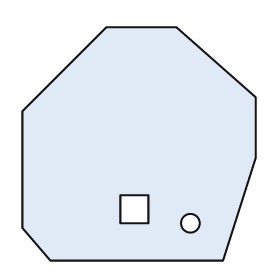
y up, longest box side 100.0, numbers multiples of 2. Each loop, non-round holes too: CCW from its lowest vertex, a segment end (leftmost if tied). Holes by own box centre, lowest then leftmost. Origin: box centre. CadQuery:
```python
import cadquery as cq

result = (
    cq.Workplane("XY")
    .moveTo(-38.0, -50.0)
    .lineTo(36.0, -50.0)
    .lineTo(50.0, -6.0)
    .lineTo(50.0, 20.0)
    .lineTo(16.0, 50.0)
    .lineTo(-14.0, 50.0)
    .lineTo(-50.0, 14.0)
    .lineTo(-50.0, -36.0)
    .close()
    .moveTo(22.0, -34.0)
    .circle(4.0)
    .moveTo(-8.0, -34.0)
    .lineTo(4.0, -34.0)
    .lineTo(4.0, -22.0)
    .lineTo(-8.0, -22.0)
    .close()
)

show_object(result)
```